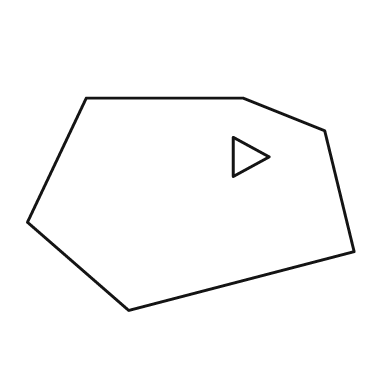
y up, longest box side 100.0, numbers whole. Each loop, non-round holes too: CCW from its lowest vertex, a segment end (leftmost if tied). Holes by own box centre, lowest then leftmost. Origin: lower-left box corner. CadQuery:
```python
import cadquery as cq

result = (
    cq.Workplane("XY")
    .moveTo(31.0, 0.0)
    .lineTo(100.0, 18.0)
    .lineTo(91.0, 55.0)
    .lineTo(66.0, 65.0)
    .lineTo(18.0, 65.0)
    .lineTo(0.0, 27.0)
    .close()
    .moveTo(63.0, 41.0)
    .lineTo(74.0, 47.0)
    .lineTo(63.0, 53.0)
    .close()
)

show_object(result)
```